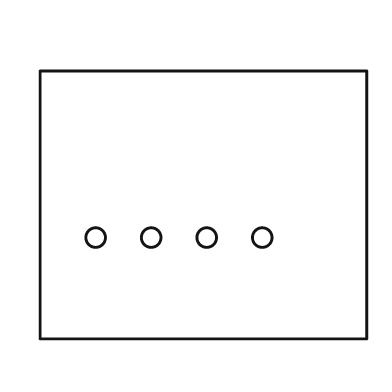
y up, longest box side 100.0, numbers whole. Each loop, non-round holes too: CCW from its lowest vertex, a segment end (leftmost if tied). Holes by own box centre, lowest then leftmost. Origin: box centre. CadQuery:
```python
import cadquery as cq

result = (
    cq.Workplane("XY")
    .moveTo(-50.0, -41.0)
    .lineTo(50.0, -41.0)
    .lineTo(50.0, 41.0)
    .lineTo(-50.0, 41.0)
    .close()
    .moveTo(-33.0, -10.0)
    .circle(3.0)
    .moveTo(-16.0, -10.0)
    .circle(3.0)
    .moveTo(1.0, -10.0)
    .circle(3.0)
    .moveTo(18.0, -10.0)
    .circle(3.0)
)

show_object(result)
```